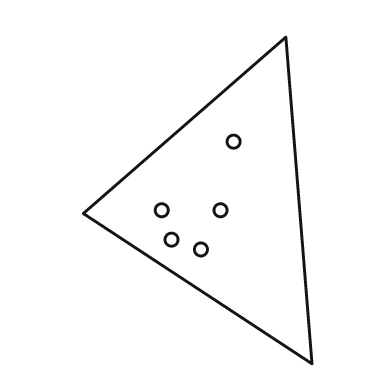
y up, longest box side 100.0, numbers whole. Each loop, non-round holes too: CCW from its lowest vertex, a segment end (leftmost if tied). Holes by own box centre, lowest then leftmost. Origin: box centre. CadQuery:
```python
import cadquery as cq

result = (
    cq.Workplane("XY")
    .moveTo(35.0, -50.0)
    .lineTo(27.0, 50.0)
    .lineTo(-35.0, -4.0)
    .close()
    .moveTo(1.0, -15.0)
    .circle(2.0)
    .moveTo(-8.0, -12.0)
    .circle(2.0)
    .moveTo(-11.0, -3.0)
    .circle(2.0)
    .moveTo(7.0, -3.0)
    .circle(2.0)
    .moveTo(11.0, 18.0)
    .circle(2.0)
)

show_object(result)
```